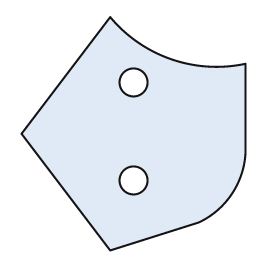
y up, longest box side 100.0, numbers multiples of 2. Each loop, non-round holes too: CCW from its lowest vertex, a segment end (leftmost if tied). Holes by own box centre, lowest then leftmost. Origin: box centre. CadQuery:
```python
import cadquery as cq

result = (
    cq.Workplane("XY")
    .moveTo(-10.0, -50.0)
    .lineTo(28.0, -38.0)
    .threePointArc((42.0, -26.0), (48.0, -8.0))
    .lineTo(48.0, 30.0)
    .threePointArc((16.0, 32.0), (-10.0, 50.0))
    .lineTo(-48.0, 0.0)
    .close()
    .moveTo(0.0, -20.0)
    .circle(6.0)
    .moveTo(0.0, 22.0)
    .circle(6.0)
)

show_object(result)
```